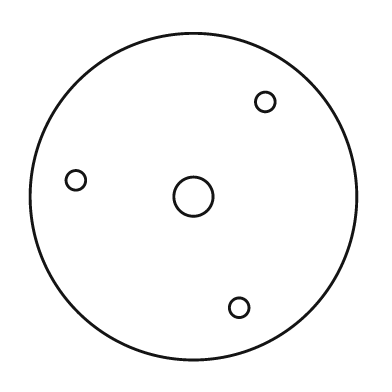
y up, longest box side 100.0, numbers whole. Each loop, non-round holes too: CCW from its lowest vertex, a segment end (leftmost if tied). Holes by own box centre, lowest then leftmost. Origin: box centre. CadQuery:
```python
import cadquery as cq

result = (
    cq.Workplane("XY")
    .moveTo(0.0, 0.0)
    .circle(50.0)
    .moveTo(14.0, -34.0)
    .circle(3.0)
    .moveTo(0.0, 0.0)
    .circle(6.0)
    .moveTo(-36.0, 5.0)
    .circle(3.0)
    .moveTo(22.0, 29.0)
    .circle(3.0)
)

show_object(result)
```